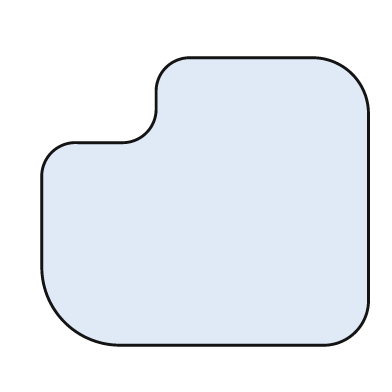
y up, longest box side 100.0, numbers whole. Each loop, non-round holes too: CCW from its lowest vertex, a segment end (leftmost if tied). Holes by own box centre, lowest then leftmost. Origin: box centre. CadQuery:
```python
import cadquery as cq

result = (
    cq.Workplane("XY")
    .moveTo(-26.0, -44.0)
    .lineTo(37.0, -44.0)
    .threePointArc((46.0, -40.0), (50.0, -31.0))
    .lineTo(50.0, 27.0)
    .threePointArc((45.0, 39.0), (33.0, 44.0))
    .lineTo(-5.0, 44.0)
    .threePointArc((-12.0, 41.0), (-15.0, 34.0))
    .lineTo(-15.0, 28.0)
    .threePointArc((-18.0, 21.0), (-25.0, 18.0))
    .lineTo(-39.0, 18.0)
    .threePointArc((-47.0, 15.0), (-50.0, 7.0))
    .lineTo(-50.0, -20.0)
    .threePointArc((-43.0, -37.0), (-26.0, -44.0))
    .close()
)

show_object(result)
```